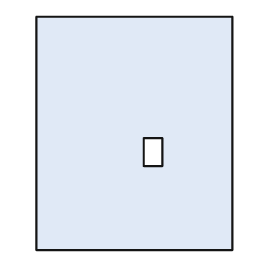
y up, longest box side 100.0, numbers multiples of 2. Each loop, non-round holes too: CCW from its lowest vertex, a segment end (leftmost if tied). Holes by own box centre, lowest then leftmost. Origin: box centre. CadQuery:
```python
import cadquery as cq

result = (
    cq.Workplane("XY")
    .moveTo(-42.0, -50.0)
    .lineTo(42.0, -50.0)
    .lineTo(42.0, 50.0)
    .lineTo(-42.0, 50.0)
    .close()
    .moveTo(4.0, -14.0)
    .lineTo(12.0, -14.0)
    .lineTo(12.0, -2.0)
    .lineTo(4.0, -2.0)
    .close()
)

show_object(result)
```